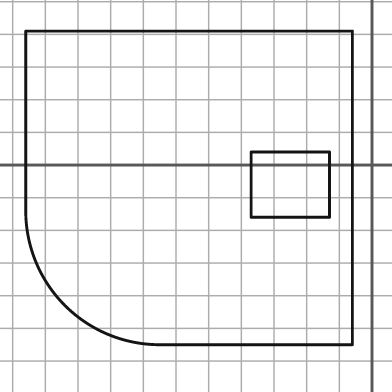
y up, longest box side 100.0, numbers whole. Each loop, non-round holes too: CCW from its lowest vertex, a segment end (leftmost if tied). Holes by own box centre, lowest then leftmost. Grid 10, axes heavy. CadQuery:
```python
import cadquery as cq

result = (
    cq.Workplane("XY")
    .moveTo(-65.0, -55.0)
    .lineTo(-6.0, -55.0)
    .lineTo(-6.0, 41.0)
    .lineTo(-106.0, 41.0)
    .lineTo(-106.0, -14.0)
    .threePointArc((-94.0, -43.0), (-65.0, -55.0))
    .close()
    .moveTo(-37.0, -16.0)
    .lineTo(-13.0, -16.0)
    .lineTo(-13.0, 4.0)
    .lineTo(-37.0, 4.0)
    .close()
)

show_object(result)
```